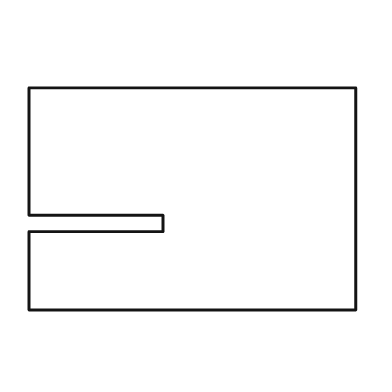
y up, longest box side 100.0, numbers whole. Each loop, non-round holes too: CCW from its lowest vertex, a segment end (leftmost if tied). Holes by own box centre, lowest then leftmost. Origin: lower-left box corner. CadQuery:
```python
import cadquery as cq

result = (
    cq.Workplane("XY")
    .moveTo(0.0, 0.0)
    .lineTo(100.0, 0.0)
    .lineTo(100.0, 68.0)
    .lineTo(0.0, 68.0)
    .lineTo(0.0, 29.0)
    .lineTo(41.0, 29.0)
    .lineTo(41.0, 24.0)
    .lineTo(0.0, 24.0)
    .close()
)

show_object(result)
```